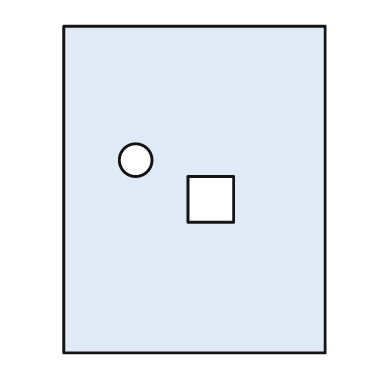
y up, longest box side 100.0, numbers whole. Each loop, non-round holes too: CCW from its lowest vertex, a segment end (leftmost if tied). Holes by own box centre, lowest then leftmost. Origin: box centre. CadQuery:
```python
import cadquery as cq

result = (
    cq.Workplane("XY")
    .moveTo(-40.0, -50.0)
    .lineTo(40.0, -50.0)
    .lineTo(40.0, 50.0)
    .lineTo(-40.0, 50.0)
    .close()
    .moveTo(-2.0, -10.0)
    .lineTo(12.0, -10.0)
    .lineTo(12.0, 4.0)
    .lineTo(-2.0, 4.0)
    .close()
    .moveTo(-18.0, 9.0)
    .circle(5.0)
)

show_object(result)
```